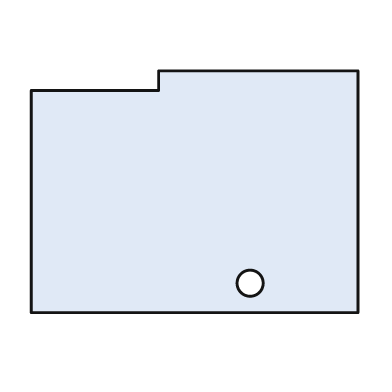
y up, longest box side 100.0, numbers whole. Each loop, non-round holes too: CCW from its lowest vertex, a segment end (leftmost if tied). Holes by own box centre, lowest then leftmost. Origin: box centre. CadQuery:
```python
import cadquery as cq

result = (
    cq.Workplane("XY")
    .moveTo(-50.0, -37.0)
    .lineTo(50.0, -37.0)
    .lineTo(50.0, 37.0)
    .lineTo(-11.0, 37.0)
    .lineTo(-11.0, 31.0)
    .lineTo(-50.0, 31.0)
    .close()
    .moveTo(17.0, -28.0)
    .circle(4.0)
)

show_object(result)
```